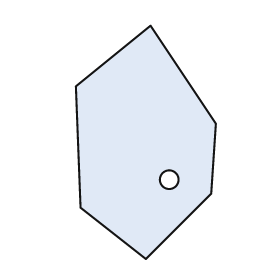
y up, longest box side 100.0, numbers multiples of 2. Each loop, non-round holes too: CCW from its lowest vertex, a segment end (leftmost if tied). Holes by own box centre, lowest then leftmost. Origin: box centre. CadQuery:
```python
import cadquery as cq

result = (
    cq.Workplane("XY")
    .moveTo(0.0, -50.0)
    .lineTo(28.0, -22.0)
    .lineTo(30.0, 8.0)
    .lineTo(2.0, 50.0)
    .lineTo(-30.0, 24.0)
    .lineTo(-28.0, -28.0)
    .close()
    .moveTo(10.0, -16.0)
    .circle(4.0)
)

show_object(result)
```